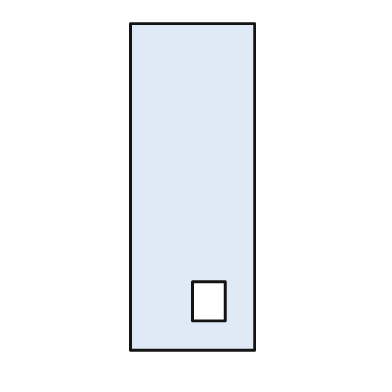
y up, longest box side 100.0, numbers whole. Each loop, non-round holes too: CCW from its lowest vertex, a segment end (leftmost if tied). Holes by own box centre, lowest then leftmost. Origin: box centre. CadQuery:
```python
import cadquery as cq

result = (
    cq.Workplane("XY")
    .moveTo(-19.0, -50.0)
    .lineTo(19.0, -50.0)
    .lineTo(19.0, 50.0)
    .lineTo(-19.0, 50.0)
    .close()
    .moveTo(0.0, -41.0)
    .lineTo(10.0, -41.0)
    .lineTo(10.0, -29.0)
    .lineTo(0.0, -29.0)
    .close()
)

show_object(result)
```